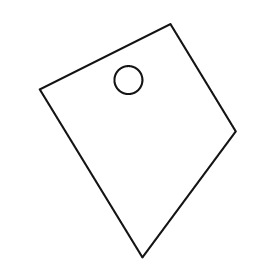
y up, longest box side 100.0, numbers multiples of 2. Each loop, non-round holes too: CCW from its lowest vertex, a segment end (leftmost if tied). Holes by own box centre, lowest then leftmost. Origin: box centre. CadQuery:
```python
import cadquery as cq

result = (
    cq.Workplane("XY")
    .moveTo(2.0, -50.0)
    .lineTo(42.0, 4.0)
    .lineTo(14.0, 50.0)
    .lineTo(-42.0, 22.0)
    .close()
    .moveTo(-4.0, 26.0)
    .circle(6.0)
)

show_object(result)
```